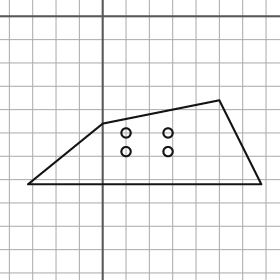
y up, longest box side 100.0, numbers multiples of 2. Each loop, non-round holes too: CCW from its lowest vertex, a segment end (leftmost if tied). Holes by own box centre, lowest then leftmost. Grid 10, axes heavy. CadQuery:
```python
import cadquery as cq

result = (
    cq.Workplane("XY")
    .moveTo(-32.0, -72.0)
    .lineTo(68.0, -72.0)
    .lineTo(50.0, -36.0)
    .lineTo(0.0, -46.0)
    .close()
    .moveTo(10.0, -58.0)
    .circle(2.0)
    .moveTo(28.0, -58.0)
    .circle(2.0)
    .moveTo(10.0, -50.0)
    .circle(2.0)
    .moveTo(28.0, -50.0)
    .circle(2.0)
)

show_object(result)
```